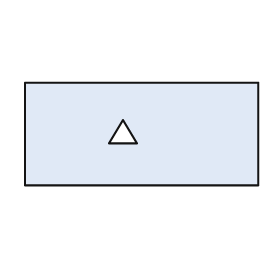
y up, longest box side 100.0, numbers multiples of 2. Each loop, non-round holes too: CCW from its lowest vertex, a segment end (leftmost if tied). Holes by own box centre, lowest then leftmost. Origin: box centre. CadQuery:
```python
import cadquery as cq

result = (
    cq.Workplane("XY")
    .moveTo(-50.0, -22.0)
    .lineTo(50.0, -22.0)
    .lineTo(50.0, 22.0)
    .lineTo(-50.0, 22.0)
    .close()
    .moveTo(-14.0, -4.0)
    .lineTo(-2.0, -4.0)
    .lineTo(-8.0, 6.0)
    .close()
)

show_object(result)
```